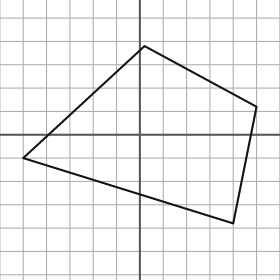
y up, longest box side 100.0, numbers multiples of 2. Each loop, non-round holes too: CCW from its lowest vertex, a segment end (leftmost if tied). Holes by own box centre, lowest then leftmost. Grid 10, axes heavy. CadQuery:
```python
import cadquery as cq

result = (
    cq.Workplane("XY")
    .moveTo(40.0, -38.0)
    .lineTo(50.0, 12.0)
    .lineTo(2.0, 38.0)
    .lineTo(-50.0, -10.0)
    .close()
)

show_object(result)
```